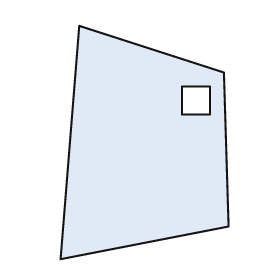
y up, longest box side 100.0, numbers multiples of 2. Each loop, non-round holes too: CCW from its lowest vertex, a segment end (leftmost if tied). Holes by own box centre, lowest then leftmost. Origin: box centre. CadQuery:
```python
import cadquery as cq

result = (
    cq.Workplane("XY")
    .moveTo(-36.0, -50.0)
    .lineTo(36.0, -36.0)
    .lineTo(34.0, 30.0)
    .lineTo(-28.0, 50.0)
    .close()
    .moveTo(16.0, 12.0)
    .lineTo(28.0, 12.0)
    .lineTo(28.0, 24.0)
    .lineTo(16.0, 24.0)
    .close()
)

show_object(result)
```